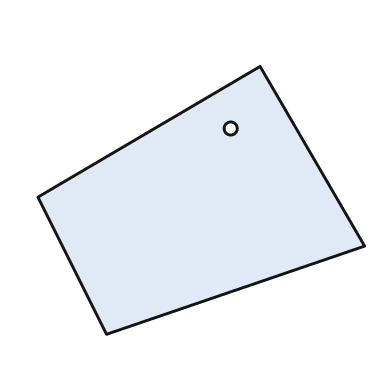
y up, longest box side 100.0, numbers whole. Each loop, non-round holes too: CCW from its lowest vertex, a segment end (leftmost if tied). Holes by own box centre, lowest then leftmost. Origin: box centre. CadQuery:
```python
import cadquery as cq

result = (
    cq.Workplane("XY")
    .moveTo(-29.0, -41.0)
    .lineTo(50.0, -14.0)
    .lineTo(18.0, 41.0)
    .lineTo(-50.0, 1.0)
    .close()
    .moveTo(9.0, 22.0)
    .circle(2.0)
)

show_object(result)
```